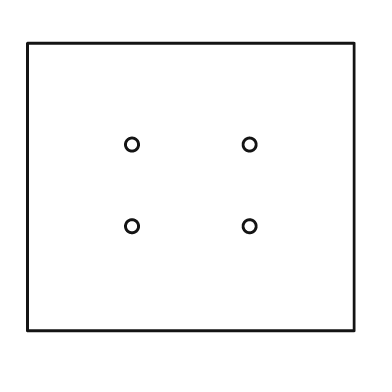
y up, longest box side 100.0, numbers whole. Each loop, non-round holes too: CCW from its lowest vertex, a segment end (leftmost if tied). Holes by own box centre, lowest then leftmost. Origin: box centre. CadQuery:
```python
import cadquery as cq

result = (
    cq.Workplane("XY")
    .moveTo(-50.0, -44.0)
    .lineTo(50.0, -44.0)
    .lineTo(50.0, 44.0)
    .lineTo(-50.0, 44.0)
    .close()
    .moveTo(-18.0, -12.0)
    .circle(2.0)
    .moveTo(18.0, -12.0)
    .circle(2.0)
    .moveTo(-18.0, 13.0)
    .circle(2.0)
    .moveTo(18.0, 13.0)
    .circle(2.0)
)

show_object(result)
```